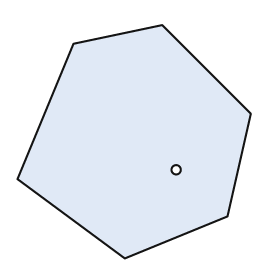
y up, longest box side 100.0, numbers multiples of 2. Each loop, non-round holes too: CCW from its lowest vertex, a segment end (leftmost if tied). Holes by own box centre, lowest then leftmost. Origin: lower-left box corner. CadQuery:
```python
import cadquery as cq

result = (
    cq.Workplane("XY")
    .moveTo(46.0, 0.0)
    .lineTo(90.0, 18.0)
    .lineTo(100.0, 62.0)
    .lineTo(62.0, 100.0)
    .lineTo(24.0, 92.0)
    .lineTo(0.0, 34.0)
    .close()
    .moveTo(68.0, 38.0)
    .circle(2.0)
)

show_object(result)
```